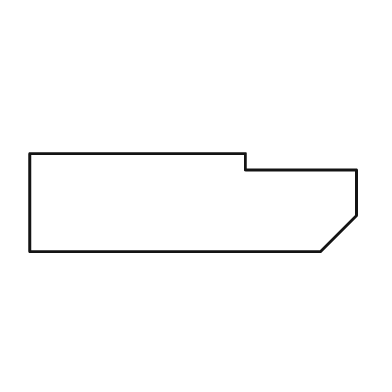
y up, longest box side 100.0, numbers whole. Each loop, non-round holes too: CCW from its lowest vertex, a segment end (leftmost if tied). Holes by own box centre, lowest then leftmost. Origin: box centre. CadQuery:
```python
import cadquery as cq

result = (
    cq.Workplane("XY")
    .moveTo(-50.0, -15.0)
    .lineTo(39.0, -15.0)
    .lineTo(50.0, -4.0)
    .lineTo(50.0, 10.0)
    .lineTo(16.0, 10.0)
    .lineTo(16.0, 15.0)
    .lineTo(-50.0, 15.0)
    .close()
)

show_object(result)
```